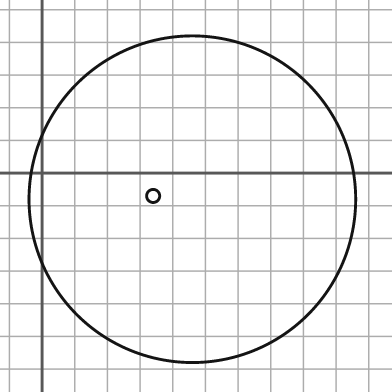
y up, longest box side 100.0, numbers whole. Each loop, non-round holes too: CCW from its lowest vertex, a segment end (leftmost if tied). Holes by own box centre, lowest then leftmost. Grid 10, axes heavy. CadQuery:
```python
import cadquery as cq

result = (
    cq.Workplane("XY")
    .moveTo(46.0, -8.0)
    .circle(50.0)
    .moveTo(34.0, -7.0)
    .circle(2.0)
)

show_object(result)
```